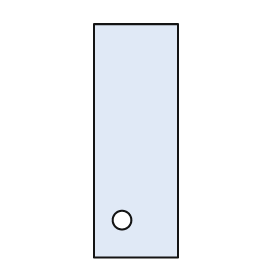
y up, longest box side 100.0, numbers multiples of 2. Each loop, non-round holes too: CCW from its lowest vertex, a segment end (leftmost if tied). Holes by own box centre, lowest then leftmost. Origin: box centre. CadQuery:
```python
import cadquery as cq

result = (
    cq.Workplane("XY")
    .moveTo(-18.0, -50.0)
    .lineTo(18.0, -50.0)
    .lineTo(18.0, 50.0)
    .lineTo(-18.0, 50.0)
    .close()
    .moveTo(-6.0, -34.0)
    .circle(4.0)
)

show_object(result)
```